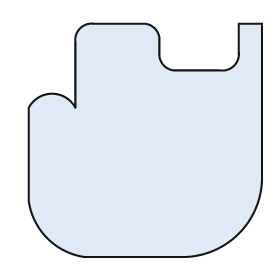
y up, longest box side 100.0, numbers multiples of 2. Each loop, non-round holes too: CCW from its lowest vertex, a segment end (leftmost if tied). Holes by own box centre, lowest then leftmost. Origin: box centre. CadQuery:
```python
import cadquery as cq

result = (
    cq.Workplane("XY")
    .moveTo(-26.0, -50.0)
    .lineTo(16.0, -50.0)
    .threePointArc((40.0, -40.0), (50.0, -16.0))
    .lineTo(50.0, 50.0)
    .lineTo(40.0, 50.0)
    .lineTo(40.0, 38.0)
    .threePointArc((38.0, 32.0), (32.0, 30.0))
    .lineTo(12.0, 30.0)
    .threePointArc((8.0, 32.0), (6.0, 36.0))
    .lineTo(6.0, 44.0)
    .threePointArc((4.0, 48.0), (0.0, 50.0))
    .lineTo(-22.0, 50.0)
    .threePointArc((-28.0, 48.0), (-30.0, 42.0))
    .lineTo(-30.0, 14.0)
    .threePointArc((-40.0, 20.0), (-50.0, 14.0))
    .lineTo(-50.0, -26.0)
    .threePointArc((-42.0, -42.0), (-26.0, -50.0))
    .close()
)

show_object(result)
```